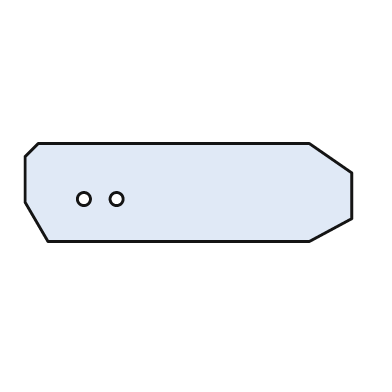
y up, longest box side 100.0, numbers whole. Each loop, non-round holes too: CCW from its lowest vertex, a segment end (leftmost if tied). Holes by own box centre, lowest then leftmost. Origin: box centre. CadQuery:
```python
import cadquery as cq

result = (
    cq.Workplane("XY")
    .moveTo(-43.0, -15.0)
    .lineTo(37.0, -15.0)
    .lineTo(50.0, -8.0)
    .lineTo(50.0, 6.0)
    .lineTo(37.0, 15.0)
    .lineTo(-46.0, 15.0)
    .lineTo(-50.0, 11.0)
    .lineTo(-50.0, -3.0)
    .close()
    .moveTo(-32.0, -2.0)
    .circle(2.0)
    .moveTo(-22.0, -2.0)
    .circle(2.0)
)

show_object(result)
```